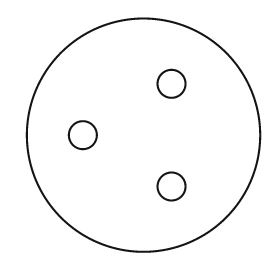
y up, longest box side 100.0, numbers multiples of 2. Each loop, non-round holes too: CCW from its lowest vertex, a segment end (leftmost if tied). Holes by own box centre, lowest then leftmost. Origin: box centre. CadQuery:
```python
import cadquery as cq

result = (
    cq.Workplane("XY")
    .moveTo(0.0, 0.0)
    .circle(50.0)
    .moveTo(12.0, -22.0)
    .circle(6.0)
    .moveTo(-26.0, 0.0)
    .circle(6.0)
    .moveTo(12.0, 22.0)
    .circle(6.0)
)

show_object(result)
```